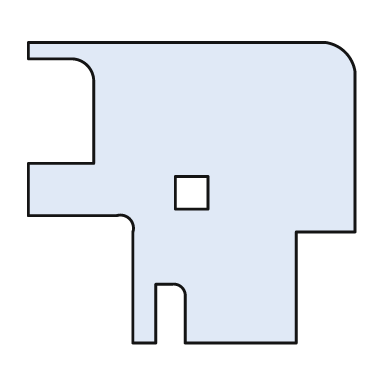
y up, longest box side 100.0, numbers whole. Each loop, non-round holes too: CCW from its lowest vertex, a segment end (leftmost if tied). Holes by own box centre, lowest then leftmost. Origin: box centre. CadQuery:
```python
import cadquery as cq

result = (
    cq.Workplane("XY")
    .moveTo(-18.0, -46.0)
    .lineTo(-11.0, -46.0)
    .lineTo(-11.0, -28.0)
    .lineTo(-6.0, -28.0)
    .threePointArc((-3.0, -29.0), (-2.0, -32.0))
    .lineTo(-2.0, -46.0)
    .lineTo(32.0, -46.0)
    .lineTo(32.0, -12.0)
    .lineTo(50.0, -12.0)
    .lineTo(50.0, 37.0)
    .threePointArc((47.0, 43.0), (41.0, 46.0))
    .lineTo(-50.0, 46.0)
    .lineTo(-50.0, 41.0)
    .lineTo(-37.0, 41.0)
    .threePointArc((-32.0, 39.0), (-30.0, 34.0))
    .lineTo(-30.0, 9.0)
    .lineTo(-50.0, 9.0)
    .lineTo(-50.0, -7.0)
    .lineTo(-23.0, -7.0)
    .threePointArc((-19.0, -8.0), (-18.0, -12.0))
    .close()
    .moveTo(-5.0, -5.0)
    .lineTo(5.0, -5.0)
    .lineTo(5.0, 5.0)
    .lineTo(-5.0, 5.0)
    .close()
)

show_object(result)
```